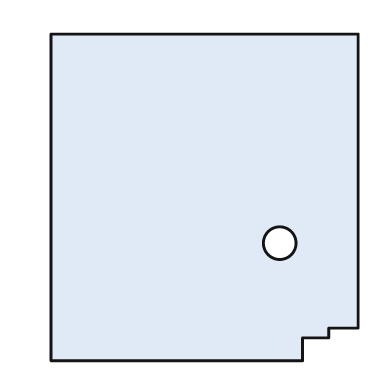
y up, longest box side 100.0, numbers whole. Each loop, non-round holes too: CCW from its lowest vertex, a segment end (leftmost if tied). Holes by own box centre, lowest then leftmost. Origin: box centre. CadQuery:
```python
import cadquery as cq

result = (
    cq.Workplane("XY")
    .moveTo(-47.0, -50.0)
    .lineTo(30.0, -50.0)
    .lineTo(30.0, -43.0)
    .lineTo(38.0, -43.0)
    .lineTo(38.0, -40.0)
    .lineTo(47.0, -40.0)
    .lineTo(47.0, 50.0)
    .lineTo(-47.0, 50.0)
    .close()
    .moveTo(23.0, -14.0)
    .circle(5.0)
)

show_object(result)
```